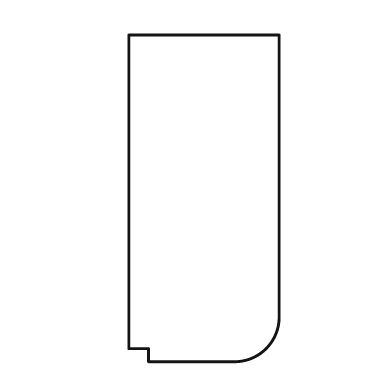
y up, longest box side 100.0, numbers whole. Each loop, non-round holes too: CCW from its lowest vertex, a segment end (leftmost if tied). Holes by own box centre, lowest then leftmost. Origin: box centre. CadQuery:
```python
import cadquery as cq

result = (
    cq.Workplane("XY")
    .moveTo(-17.0, -50.0)
    .lineTo(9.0, -50.0)
    .threePointArc((19.0, -46.0), (23.0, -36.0))
    .lineTo(23.0, 50.0)
    .lineTo(-23.0, 50.0)
    .lineTo(-23.0, -46.0)
    .lineTo(-17.0, -46.0)
    .close()
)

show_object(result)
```